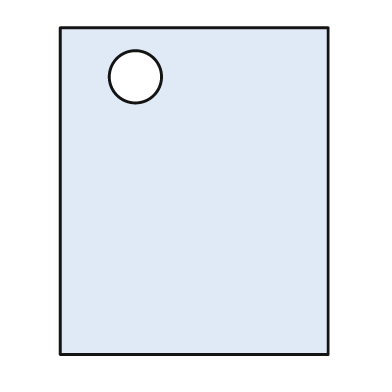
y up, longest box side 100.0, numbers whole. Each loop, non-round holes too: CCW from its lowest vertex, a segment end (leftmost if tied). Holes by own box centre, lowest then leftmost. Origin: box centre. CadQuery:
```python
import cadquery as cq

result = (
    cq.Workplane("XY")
    .moveTo(-41.0, -50.0)
    .lineTo(41.0, -50.0)
    .lineTo(41.0, 50.0)
    .lineTo(-41.0, 50.0)
    .close()
    .moveTo(-18.0, 35.0)
    .circle(8.0)
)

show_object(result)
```